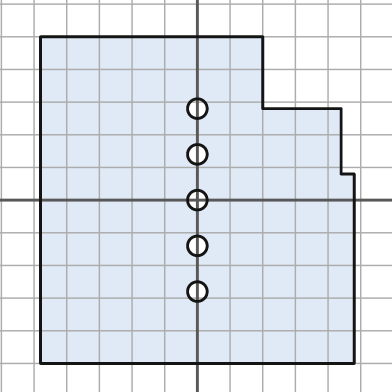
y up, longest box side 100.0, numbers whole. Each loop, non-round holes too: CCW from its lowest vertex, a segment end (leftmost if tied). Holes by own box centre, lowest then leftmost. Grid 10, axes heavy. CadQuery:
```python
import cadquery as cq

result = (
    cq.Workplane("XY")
    .moveTo(-48.0, -50.0)
    .lineTo(48.0, -50.0)
    .lineTo(48.0, 8.0)
    .lineTo(44.0, 8.0)
    .lineTo(44.0, 28.0)
    .lineTo(20.0, 28.0)
    .lineTo(20.0, 50.0)
    .lineTo(-48.0, 50.0)
    .close()
    .moveTo(0.0, -28.0)
    .circle(3.0)
    .moveTo(0.0, -14.0)
    .circle(3.0)
    .moveTo(0.0, 0.0)
    .circle(3.0)
    .moveTo(0.0, 14.0)
    .circle(3.0)
    .moveTo(0.0, 28.0)
    .circle(3.0)
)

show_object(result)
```